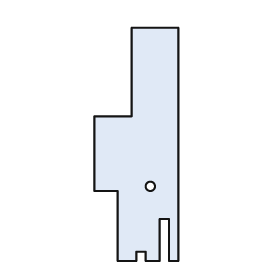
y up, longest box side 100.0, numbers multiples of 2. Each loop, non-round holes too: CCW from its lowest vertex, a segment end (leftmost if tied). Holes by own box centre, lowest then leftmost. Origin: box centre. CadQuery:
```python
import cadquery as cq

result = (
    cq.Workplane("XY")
    .moveTo(-8.0, -50.0)
    .lineTo(0.0, -50.0)
    .lineTo(0.0, -46.0)
    .lineTo(4.0, -46.0)
    .lineTo(4.0, -50.0)
    .lineTo(10.0, -50.0)
    .lineTo(10.0, -32.0)
    .lineTo(14.0, -32.0)
    .lineTo(14.0, -50.0)
    .lineTo(18.0, -50.0)
    .lineTo(18.0, 50.0)
    .lineTo(-2.0, 50.0)
    .lineTo(-2.0, 12.0)
    .lineTo(-18.0, 12.0)
    .lineTo(-18.0, -20.0)
    .lineTo(-8.0, -20.0)
    .close()
    .moveTo(6.0, -18.0)
    .circle(2.0)
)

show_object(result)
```